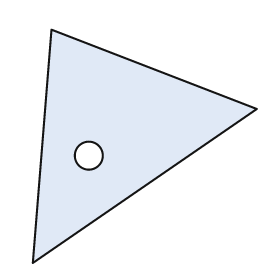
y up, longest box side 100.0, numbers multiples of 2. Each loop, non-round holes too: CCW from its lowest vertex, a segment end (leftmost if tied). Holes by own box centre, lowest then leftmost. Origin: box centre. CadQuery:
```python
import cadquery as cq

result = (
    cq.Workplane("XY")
    .moveTo(-48.0, -50.0)
    .lineTo(48.0, 16.0)
    .lineTo(-40.0, 50.0)
    .close()
    .moveTo(-24.0, -4.0)
    .circle(6.0)
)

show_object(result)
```